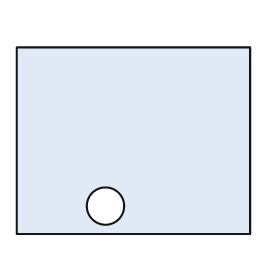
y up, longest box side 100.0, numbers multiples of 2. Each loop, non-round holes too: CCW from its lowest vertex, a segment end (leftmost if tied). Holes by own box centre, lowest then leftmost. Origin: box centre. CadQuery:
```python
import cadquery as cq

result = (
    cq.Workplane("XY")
    .moveTo(-50.0, -40.0)
    .lineTo(50.0, -40.0)
    .lineTo(50.0, 40.0)
    .lineTo(-50.0, 40.0)
    .close()
    .moveTo(-12.0, -28.0)
    .circle(8.0)
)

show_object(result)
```